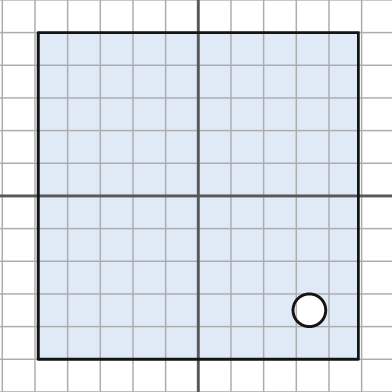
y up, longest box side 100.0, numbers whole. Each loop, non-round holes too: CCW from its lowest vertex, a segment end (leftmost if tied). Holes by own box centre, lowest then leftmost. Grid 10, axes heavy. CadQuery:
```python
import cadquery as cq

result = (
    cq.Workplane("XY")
    .moveTo(-49.0, -50.0)
    .lineTo(49.0, -50.0)
    .lineTo(49.0, 50.0)
    .lineTo(-49.0, 50.0)
    .close()
    .moveTo(34.0, -35.0)
    .circle(5.0)
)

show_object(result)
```